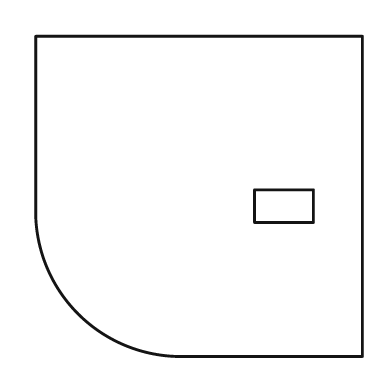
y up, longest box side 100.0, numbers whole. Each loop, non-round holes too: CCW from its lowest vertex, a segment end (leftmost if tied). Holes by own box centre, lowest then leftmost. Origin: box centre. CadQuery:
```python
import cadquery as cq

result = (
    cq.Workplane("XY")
    .moveTo(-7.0, -49.0)
    .lineTo(50.0, -49.0)
    .lineTo(50.0, 49.0)
    .lineTo(-50.0, 49.0)
    .lineTo(-50.0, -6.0)
    .threePointArc((-37.0, -36.0), (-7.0, -49.0))
    .close()
    .moveTo(17.0, -8.0)
    .lineTo(35.0, -8.0)
    .lineTo(35.0, 2.0)
    .lineTo(17.0, 2.0)
    .close()
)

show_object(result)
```